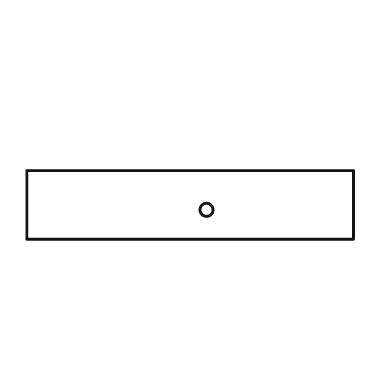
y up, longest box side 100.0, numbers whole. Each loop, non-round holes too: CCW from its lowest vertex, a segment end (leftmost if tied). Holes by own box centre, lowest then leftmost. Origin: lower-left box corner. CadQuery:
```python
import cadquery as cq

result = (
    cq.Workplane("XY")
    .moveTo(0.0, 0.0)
    .lineTo(100.0, 0.0)
    .lineTo(100.0, 21.0)
    .lineTo(0.0, 21.0)
    .close()
    .moveTo(55.0, 9.0)
    .circle(2.0)
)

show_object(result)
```